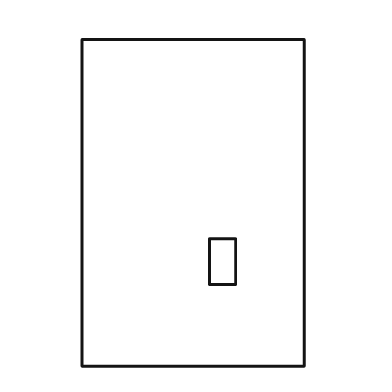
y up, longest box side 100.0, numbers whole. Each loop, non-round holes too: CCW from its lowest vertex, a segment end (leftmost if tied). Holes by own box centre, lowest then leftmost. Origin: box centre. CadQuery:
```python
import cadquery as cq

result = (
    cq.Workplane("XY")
    .moveTo(-34.0, -50.0)
    .lineTo(34.0, -50.0)
    .lineTo(34.0, 50.0)
    .lineTo(-34.0, 50.0)
    .close()
    .moveTo(5.0, -25.0)
    .lineTo(13.0, -25.0)
    .lineTo(13.0, -11.0)
    .lineTo(5.0, -11.0)
    .close()
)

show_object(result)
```